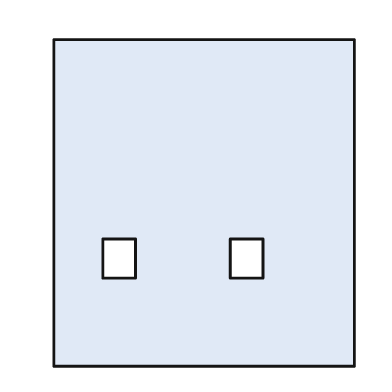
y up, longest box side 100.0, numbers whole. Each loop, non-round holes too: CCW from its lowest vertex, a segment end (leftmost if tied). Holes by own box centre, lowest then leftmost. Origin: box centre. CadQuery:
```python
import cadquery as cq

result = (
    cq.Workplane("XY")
    .moveTo(-46.0, -50.0)
    .lineTo(46.0, -50.0)
    .lineTo(46.0, 50.0)
    .lineTo(-46.0, 50.0)
    .close()
    .moveTo(-31.0, -23.0)
    .lineTo(-21.0, -23.0)
    .lineTo(-21.0, -11.0)
    .lineTo(-31.0, -11.0)
    .close()
    .moveTo(8.0, -23.0)
    .lineTo(18.0, -23.0)
    .lineTo(18.0, -11.0)
    .lineTo(8.0, -11.0)
    .close()
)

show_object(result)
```